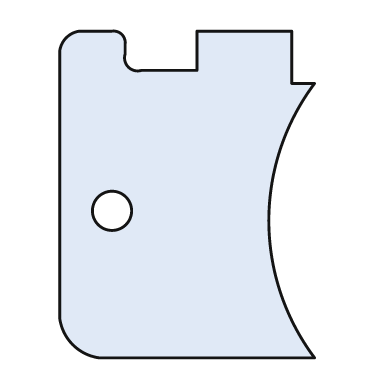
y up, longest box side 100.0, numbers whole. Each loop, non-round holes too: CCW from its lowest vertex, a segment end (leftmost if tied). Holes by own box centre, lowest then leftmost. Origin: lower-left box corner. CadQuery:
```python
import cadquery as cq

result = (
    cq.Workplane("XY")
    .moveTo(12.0, 0.0)
    .lineTo(78.0, 0.0)
    .threePointArc((64.0, 42.0), (78.0, 84.0))
    .lineTo(71.0, 84.0)
    .lineTo(71.0, 100.0)
    .lineTo(42.0, 100.0)
    .lineTo(42.0, 88.0)
    .lineTo(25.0, 88.0)
    .threePointArc((21.0, 89.0), (20.0, 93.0))
    .lineTo(20.0, 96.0)
    .threePointArc((19.0, 99.0), (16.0, 100.0))
    .lineTo(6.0, 100.0)
    .threePointArc((2.0, 98.0), (0.0, 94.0))
    .lineTo(0.0, 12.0)
    .threePointArc((4.0, 4.0), (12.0, 0.0))
    .close()
    .moveTo(16.0, 45.0)
    .circle(6.0)
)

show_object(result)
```